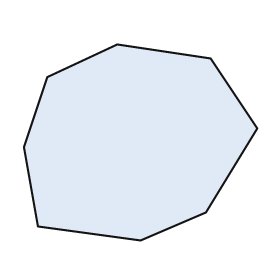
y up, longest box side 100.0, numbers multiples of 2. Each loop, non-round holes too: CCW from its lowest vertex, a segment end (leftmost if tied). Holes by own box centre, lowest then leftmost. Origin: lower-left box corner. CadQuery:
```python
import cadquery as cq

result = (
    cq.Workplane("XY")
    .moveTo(50.0, 0.0)
    .lineTo(78.0, 12.0)
    .lineTo(100.0, 48.0)
    .lineTo(80.0, 78.0)
    .lineTo(40.0, 84.0)
    .lineTo(10.0, 70.0)
    .lineTo(0.0, 40.0)
    .lineTo(6.0, 6.0)
    .close()
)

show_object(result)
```